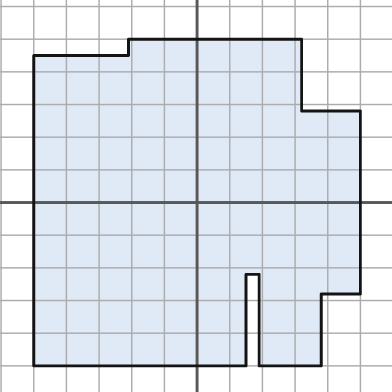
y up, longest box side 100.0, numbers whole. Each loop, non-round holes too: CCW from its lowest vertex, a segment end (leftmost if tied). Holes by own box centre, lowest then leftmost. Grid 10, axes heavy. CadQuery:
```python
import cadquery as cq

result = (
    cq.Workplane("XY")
    .moveTo(-50.0, -50.0)
    .lineTo(15.0, -50.0)
    .lineTo(15.0, -22.0)
    .lineTo(19.0, -22.0)
    .lineTo(19.0, -50.0)
    .lineTo(38.0, -50.0)
    .lineTo(38.0, -28.0)
    .lineTo(50.0, -28.0)
    .lineTo(50.0, 28.0)
    .lineTo(32.0, 28.0)
    .lineTo(32.0, 50.0)
    .lineTo(-21.0, 50.0)
    .lineTo(-21.0, 45.0)
    .lineTo(-50.0, 45.0)
    .close()
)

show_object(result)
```